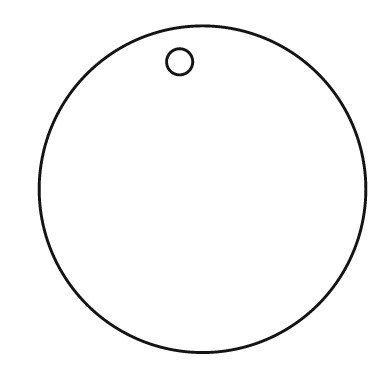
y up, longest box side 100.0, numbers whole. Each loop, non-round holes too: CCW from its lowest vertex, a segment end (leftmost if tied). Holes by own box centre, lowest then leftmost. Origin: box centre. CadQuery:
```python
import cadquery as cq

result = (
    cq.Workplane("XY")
    .moveTo(0.0, 0.0)
    .circle(50.0)
    .moveTo(-7.0, 39.0)
    .circle(4.0)
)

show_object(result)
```